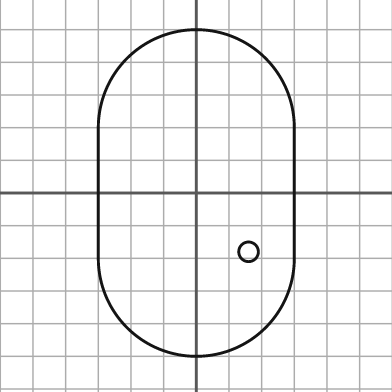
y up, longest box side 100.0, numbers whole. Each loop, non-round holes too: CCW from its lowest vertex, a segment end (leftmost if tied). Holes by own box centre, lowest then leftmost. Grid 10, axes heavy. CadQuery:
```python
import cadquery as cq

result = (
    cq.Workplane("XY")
    .moveTo(-30.0, -20.0)
    .threePointArc((0.0, -50.0), (30.0, -20.0))
    .lineTo(30.0, 20.0)
    .threePointArc((0.0, 50.0), (-30.0, 20.0))
    .close()
    .moveTo(16.0, -18.0)
    .circle(3.0)
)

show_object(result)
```